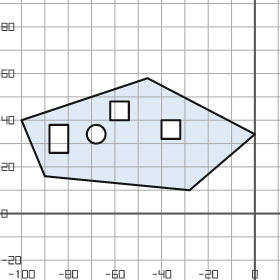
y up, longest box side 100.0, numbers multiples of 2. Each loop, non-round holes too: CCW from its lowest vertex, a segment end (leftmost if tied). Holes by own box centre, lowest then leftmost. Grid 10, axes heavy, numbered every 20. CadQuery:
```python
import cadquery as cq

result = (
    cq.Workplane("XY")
    .moveTo(-28.0, 10.0)
    .lineTo(0.0, 34.0)
    .lineTo(-46.0, 58.0)
    .lineTo(-100.0, 40.0)
    .lineTo(-90.0, 16.0)
    .close()
    .moveTo(-88.0, 26.0)
    .lineTo(-80.0, 26.0)
    .lineTo(-80.0, 38.0)
    .lineTo(-88.0, 38.0)
    .close()
    .moveTo(-68.0, 34.0)
    .circle(4.0)
    .moveTo(-40.0, 32.0)
    .lineTo(-32.0, 32.0)
    .lineTo(-32.0, 40.0)
    .lineTo(-40.0, 40.0)
    .close()
    .moveTo(-62.0, 40.0)
    .lineTo(-54.0, 40.0)
    .lineTo(-54.0, 48.0)
    .lineTo(-62.0, 48.0)
    .close()
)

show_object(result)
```